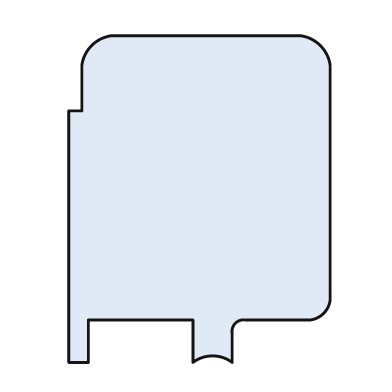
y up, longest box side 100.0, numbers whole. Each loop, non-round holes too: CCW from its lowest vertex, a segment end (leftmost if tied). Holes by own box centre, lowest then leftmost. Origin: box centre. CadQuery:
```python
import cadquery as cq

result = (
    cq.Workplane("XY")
    .moveTo(-40.0, -50.0)
    .lineTo(-34.0, -50.0)
    .lineTo(-34.0, -37.0)
    .lineTo(-2.0, -37.0)
    .lineTo(-2.0, -50.0)
    .threePointArc((4.0, -48.0), (10.0, -50.0))
    .lineTo(10.0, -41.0)
    .threePointArc((11.0, -38.0), (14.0, -37.0))
    .lineTo(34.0, -37.0)
    .threePointArc((38.0, -35.0), (40.0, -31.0))
    .lineTo(40.0, 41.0)
    .threePointArc((37.0, 47.0), (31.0, 50.0))
    .lineTo(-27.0, 50.0)
    .threePointArc((-33.0, 47.0), (-36.0, 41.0))
    .lineTo(-36.0, 27.0)
    .lineTo(-40.0, 27.0)
    .close()
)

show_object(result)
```